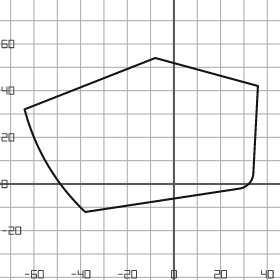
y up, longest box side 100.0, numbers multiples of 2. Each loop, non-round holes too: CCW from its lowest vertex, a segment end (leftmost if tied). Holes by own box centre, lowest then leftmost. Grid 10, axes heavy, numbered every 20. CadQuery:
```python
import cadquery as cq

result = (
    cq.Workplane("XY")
    .moveTo(-38.0, -12.0)
    .lineTo(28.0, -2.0)
    .threePointArc((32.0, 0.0), (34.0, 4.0))
    .lineTo(36.0, 42.0)
    .lineTo(-8.0, 54.0)
    .lineTo(-64.0, 32.0)
    .threePointArc((-54.0, 8.0), (-38.0, -12.0))
    .close()
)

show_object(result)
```